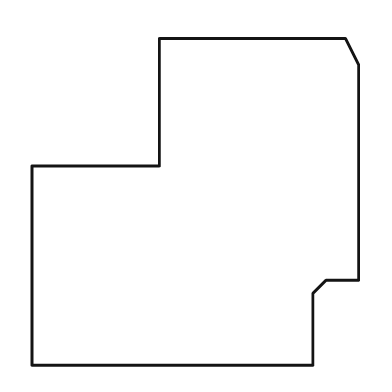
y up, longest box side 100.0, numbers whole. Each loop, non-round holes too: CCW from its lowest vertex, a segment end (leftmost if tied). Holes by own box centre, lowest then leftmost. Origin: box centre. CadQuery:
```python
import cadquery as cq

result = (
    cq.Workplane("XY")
    .moveTo(-50.0, -50.0)
    .lineTo(36.0, -50.0)
    .lineTo(36.0, -28.0)
    .lineTo(40.0, -24.0)
    .lineTo(50.0, -24.0)
    .lineTo(50.0, 42.0)
    .lineTo(46.0, 50.0)
    .lineTo(-11.0, 50.0)
    .lineTo(-11.0, 11.0)
    .lineTo(-50.0, 11.0)
    .close()
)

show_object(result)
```